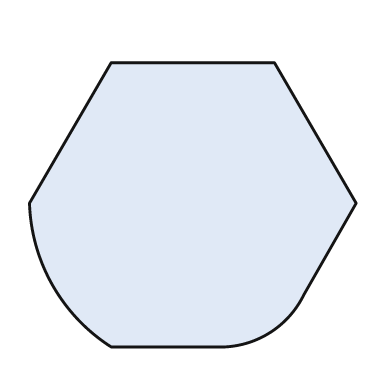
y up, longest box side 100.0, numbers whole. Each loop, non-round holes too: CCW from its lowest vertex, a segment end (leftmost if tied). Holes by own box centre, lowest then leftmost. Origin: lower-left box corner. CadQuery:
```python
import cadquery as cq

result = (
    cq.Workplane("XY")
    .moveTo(25.0, 0.0)
    .lineTo(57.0, 0.0)
    .threePointArc((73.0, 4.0), (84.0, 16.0))
    .lineTo(100.0, 44.0)
    .lineTo(75.0, 87.0)
    .lineTo(25.0, 87.0)
    .lineTo(0.0, 44.0)
    .threePointArc((7.0, 19.0), (25.0, 0.0))
    .close()
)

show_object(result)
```